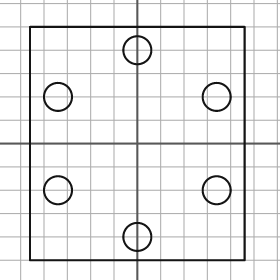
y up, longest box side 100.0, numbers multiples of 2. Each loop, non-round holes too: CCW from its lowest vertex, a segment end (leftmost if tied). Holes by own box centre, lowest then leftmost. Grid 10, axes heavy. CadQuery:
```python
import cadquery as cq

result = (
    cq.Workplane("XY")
    .moveTo(-46.0, -50.0)
    .lineTo(46.0, -50.0)
    .lineTo(46.0, 50.0)
    .lineTo(-46.0, 50.0)
    .close()
    .moveTo(0.0, -40.0)
    .circle(6.0)
    .moveTo(-34.0, -20.0)
    .circle(6.0)
    .moveTo(34.0, -20.0)
    .circle(6.0)
    .moveTo(-34.0, 20.0)
    .circle(6.0)
    .moveTo(34.0, 20.0)
    .circle(6.0)
    .moveTo(0.0, 40.0)
    .circle(6.0)
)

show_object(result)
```